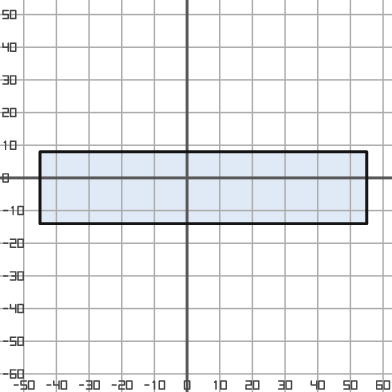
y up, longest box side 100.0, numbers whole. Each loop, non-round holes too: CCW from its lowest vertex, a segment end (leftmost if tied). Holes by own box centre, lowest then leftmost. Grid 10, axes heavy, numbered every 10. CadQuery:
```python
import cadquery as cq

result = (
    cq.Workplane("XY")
    .moveTo(-45.0, -14.0)
    .lineTo(55.0, -14.0)
    .lineTo(55.0, 8.0)
    .lineTo(-45.0, 8.0)
    .close()
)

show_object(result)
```